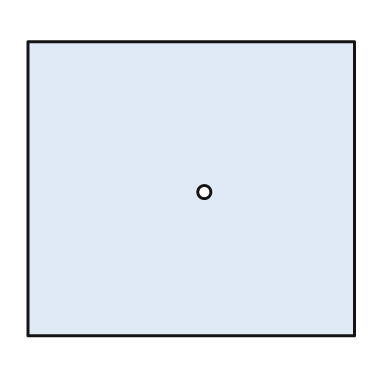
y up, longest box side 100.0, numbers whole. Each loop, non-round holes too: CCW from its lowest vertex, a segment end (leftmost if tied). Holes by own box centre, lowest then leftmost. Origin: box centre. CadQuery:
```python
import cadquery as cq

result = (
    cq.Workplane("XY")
    .moveTo(-50.0, -45.0)
    .lineTo(50.0, -45.0)
    .lineTo(50.0, 45.0)
    .lineTo(-50.0, 45.0)
    .close()
    .moveTo(4.0, -1.0)
    .circle(2.0)
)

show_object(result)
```